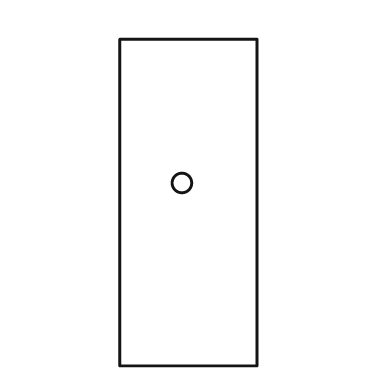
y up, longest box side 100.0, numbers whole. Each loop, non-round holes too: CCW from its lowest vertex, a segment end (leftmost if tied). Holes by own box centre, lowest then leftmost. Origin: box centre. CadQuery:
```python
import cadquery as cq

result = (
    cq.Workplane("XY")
    .moveTo(-21.0, -50.0)
    .lineTo(21.0, -50.0)
    .lineTo(21.0, 50.0)
    .lineTo(-21.0, 50.0)
    .close()
    .moveTo(-2.0, 6.0)
    .circle(3.0)
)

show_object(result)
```